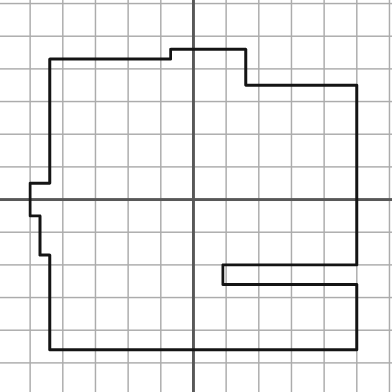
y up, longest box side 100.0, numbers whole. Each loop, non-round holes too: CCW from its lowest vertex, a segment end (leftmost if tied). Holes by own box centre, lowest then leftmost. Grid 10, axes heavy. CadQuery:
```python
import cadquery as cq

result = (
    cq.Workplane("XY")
    .moveTo(-44.0, -46.0)
    .lineTo(50.0, -46.0)
    .lineTo(50.0, -26.0)
    .lineTo(9.0, -26.0)
    .lineTo(9.0, -20.0)
    .lineTo(50.0, -20.0)
    .lineTo(50.0, 35.0)
    .lineTo(16.0, 35.0)
    .lineTo(16.0, 46.0)
    .lineTo(-7.0, 46.0)
    .lineTo(-7.0, 43.0)
    .lineTo(-44.0, 43.0)
    .lineTo(-44.0, 5.0)
    .lineTo(-50.0, 5.0)
    .lineTo(-50.0, -5.0)
    .lineTo(-47.0, -5.0)
    .lineTo(-47.0, -17.0)
    .lineTo(-44.0, -17.0)
    .close()
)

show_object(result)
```